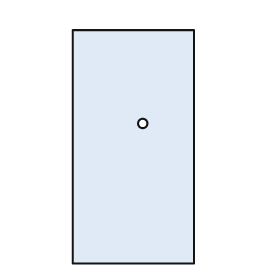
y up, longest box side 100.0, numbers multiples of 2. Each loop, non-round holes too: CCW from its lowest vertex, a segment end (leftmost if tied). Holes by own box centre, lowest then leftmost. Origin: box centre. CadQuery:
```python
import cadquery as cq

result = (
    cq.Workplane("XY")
    .moveTo(-26.0, -50.0)
    .lineTo(26.0, -50.0)
    .lineTo(26.0, 50.0)
    .lineTo(-26.0, 50.0)
    .close()
    .moveTo(4.0, 10.0)
    .circle(2.0)
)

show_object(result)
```